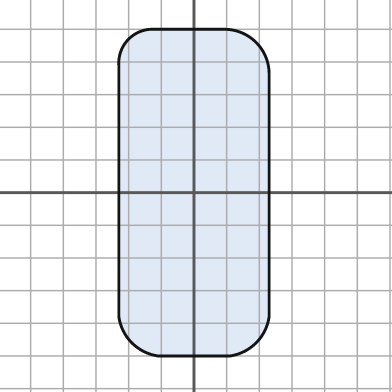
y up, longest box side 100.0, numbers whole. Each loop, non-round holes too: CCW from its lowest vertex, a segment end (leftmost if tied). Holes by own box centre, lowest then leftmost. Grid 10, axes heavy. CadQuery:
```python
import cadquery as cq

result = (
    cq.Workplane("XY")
    .moveTo(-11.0, -50.0)
    .lineTo(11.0, -50.0)
    .threePointArc((19.0, -46.0), (23.0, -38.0))
    .lineTo(23.0, 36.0)
    .threePointArc((19.0, 46.0), (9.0, 50.0))
    .lineTo(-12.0, 50.0)
    .threePointArc((-20.0, 47.0), (-23.0, 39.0))
    .lineTo(-23.0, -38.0)
    .threePointArc((-19.0, -46.0), (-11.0, -50.0))
    .close()
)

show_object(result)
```